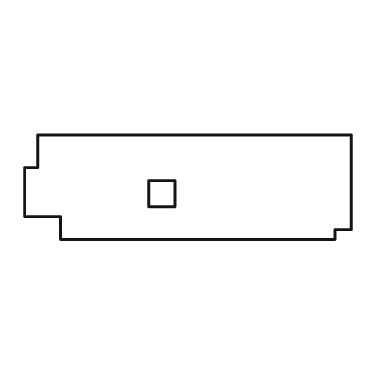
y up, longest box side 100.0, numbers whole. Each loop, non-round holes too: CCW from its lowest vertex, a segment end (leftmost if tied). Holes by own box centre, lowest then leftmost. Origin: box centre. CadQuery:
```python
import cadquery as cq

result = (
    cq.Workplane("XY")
    .moveTo(-39.0, -16.0)
    .lineTo(45.0, -16.0)
    .lineTo(45.0, -13.0)
    .lineTo(50.0, -13.0)
    .lineTo(50.0, 16.0)
    .lineTo(-46.0, 16.0)
    .lineTo(-46.0, 6.0)
    .lineTo(-50.0, 6.0)
    .lineTo(-50.0, -9.0)
    .lineTo(-39.0, -9.0)
    .close()
    .moveTo(-12.0, -6.0)
    .lineTo(-4.0, -6.0)
    .lineTo(-4.0, 2.0)
    .lineTo(-12.0, 2.0)
    .close()
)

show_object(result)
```